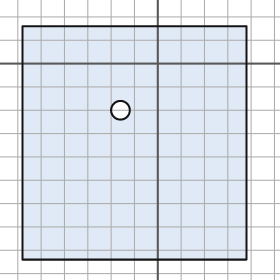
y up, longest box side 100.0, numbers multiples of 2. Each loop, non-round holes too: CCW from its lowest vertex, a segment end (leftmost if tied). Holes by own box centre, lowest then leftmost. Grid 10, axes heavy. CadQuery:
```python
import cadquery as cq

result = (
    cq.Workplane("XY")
    .moveTo(-58.0, -84.0)
    .lineTo(38.0, -84.0)
    .lineTo(38.0, 16.0)
    .lineTo(-58.0, 16.0)
    .close()
    .moveTo(-16.0, -20.0)
    .circle(4.0)
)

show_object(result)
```